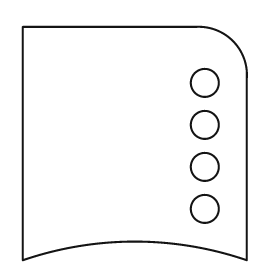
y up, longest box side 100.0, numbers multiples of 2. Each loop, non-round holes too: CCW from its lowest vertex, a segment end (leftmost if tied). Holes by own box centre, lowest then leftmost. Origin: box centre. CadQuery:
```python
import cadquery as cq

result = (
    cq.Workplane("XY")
    .moveTo(-48.0, -50.0)
    .threePointArc((0.0, -42.0), (48.0, -50.0))
    .lineTo(48.0, 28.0)
    .threePointArc((42.0, 44.0), (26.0, 50.0))
    .lineTo(-48.0, 50.0)
    .close()
    .moveTo(30.0, -28.0)
    .circle(6.0)
    .moveTo(30.0, -10.0)
    .circle(6.0)
    .moveTo(30.0, 8.0)
    .circle(6.0)
    .moveTo(30.0, 26.0)
    .circle(6.0)
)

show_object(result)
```